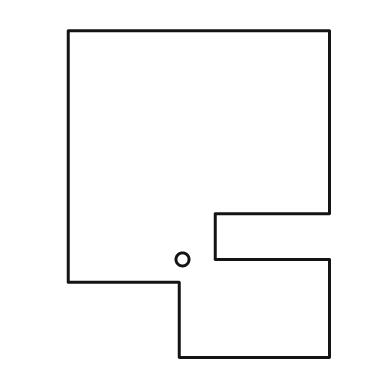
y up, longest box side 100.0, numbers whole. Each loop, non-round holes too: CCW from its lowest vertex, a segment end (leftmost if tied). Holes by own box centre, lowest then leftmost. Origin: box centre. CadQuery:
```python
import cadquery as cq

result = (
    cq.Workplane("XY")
    .moveTo(-6.0, -50.0)
    .lineTo(40.0, -50.0)
    .lineTo(40.0, -20.0)
    .lineTo(5.0, -20.0)
    .lineTo(5.0, -6.0)
    .lineTo(40.0, -6.0)
    .lineTo(40.0, 50.0)
    .lineTo(-40.0, 50.0)
    .lineTo(-40.0, -27.0)
    .lineTo(-6.0, -27.0)
    .close()
    .moveTo(-5.0, -20.0)
    .circle(2.0)
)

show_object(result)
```